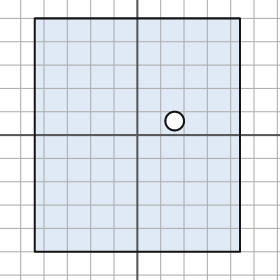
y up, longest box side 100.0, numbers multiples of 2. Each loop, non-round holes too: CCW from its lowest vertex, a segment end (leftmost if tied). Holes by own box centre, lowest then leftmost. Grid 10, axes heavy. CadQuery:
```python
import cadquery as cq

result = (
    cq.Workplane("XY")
    .moveTo(-44.0, -50.0)
    .lineTo(44.0, -50.0)
    .lineTo(44.0, 50.0)
    .lineTo(-44.0, 50.0)
    .close()
    .moveTo(16.0, 6.0)
    .circle(4.0)
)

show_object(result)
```